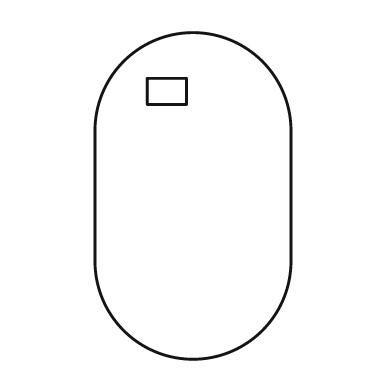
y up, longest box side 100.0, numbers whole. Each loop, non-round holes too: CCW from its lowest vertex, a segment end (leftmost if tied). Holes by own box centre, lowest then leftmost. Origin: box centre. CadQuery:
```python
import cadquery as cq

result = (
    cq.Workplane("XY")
    .moveTo(-30.0, -20.0)
    .threePointArc((0.0, -50.0), (30.0, -20.0))
    .lineTo(30.0, 20.0)
    .threePointArc((0.0, 50.0), (-30.0, 20.0))
    .close()
    .moveTo(-14.0, 28.0)
    .lineTo(-2.0, 28.0)
    .lineTo(-2.0, 36.0)
    .lineTo(-14.0, 36.0)
    .close()
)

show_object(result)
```